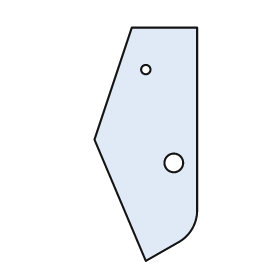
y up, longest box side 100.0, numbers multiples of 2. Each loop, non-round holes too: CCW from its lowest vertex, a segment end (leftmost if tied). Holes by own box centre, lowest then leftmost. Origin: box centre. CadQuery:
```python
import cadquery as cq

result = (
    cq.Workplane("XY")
    .moveTo(0.0, -50.0)
    .lineTo(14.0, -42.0)
    .threePointArc((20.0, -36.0), (22.0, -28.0))
    .lineTo(22.0, 50.0)
    .lineTo(-6.0, 50.0)
    .lineTo(-22.0, 2.0)
    .close()
    .moveTo(12.0, -8.0)
    .circle(4.0)
    .moveTo(0.0, 32.0)
    .circle(2.0)
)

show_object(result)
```